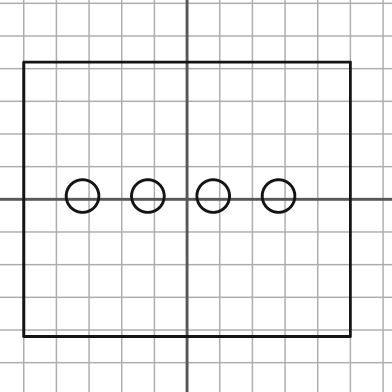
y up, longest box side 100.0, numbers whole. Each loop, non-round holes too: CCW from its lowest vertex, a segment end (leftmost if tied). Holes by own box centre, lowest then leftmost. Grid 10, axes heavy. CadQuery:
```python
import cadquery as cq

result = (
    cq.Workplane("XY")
    .moveTo(-50.0, -42.0)
    .lineTo(50.0, -42.0)
    .lineTo(50.0, 42.0)
    .lineTo(-50.0, 42.0)
    .close()
    .moveTo(-32.0, 1.0)
    .circle(5.0)
    .moveTo(-12.0, 1.0)
    .circle(5.0)
    .moveTo(8.0, 1.0)
    .circle(5.0)
    .moveTo(28.0, 1.0)
    .circle(5.0)
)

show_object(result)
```